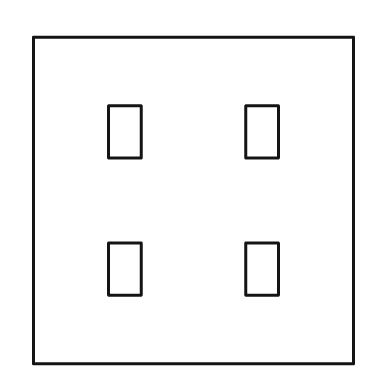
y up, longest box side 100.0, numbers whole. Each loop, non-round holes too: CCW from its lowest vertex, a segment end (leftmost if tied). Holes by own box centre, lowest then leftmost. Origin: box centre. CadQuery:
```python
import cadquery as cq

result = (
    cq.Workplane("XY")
    .moveTo(-49.0, -50.0)
    .lineTo(49.0, -50.0)
    .lineTo(49.0, 50.0)
    .lineTo(-49.0, 50.0)
    .close()
    .moveTo(-26.0, -29.0)
    .lineTo(-16.0, -29.0)
    .lineTo(-16.0, -13.0)
    .lineTo(-26.0, -13.0)
    .close()
    .moveTo(16.0, -29.0)
    .lineTo(26.0, -29.0)
    .lineTo(26.0, -13.0)
    .lineTo(16.0, -13.0)
    .close()
    .moveTo(-26.0, 13.0)
    .lineTo(-16.0, 13.0)
    .lineTo(-16.0, 29.0)
    .lineTo(-26.0, 29.0)
    .close()
    .moveTo(16.0, 13.0)
    .lineTo(26.0, 13.0)
    .lineTo(26.0, 29.0)
    .lineTo(16.0, 29.0)
    .close()
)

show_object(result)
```